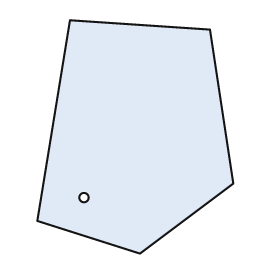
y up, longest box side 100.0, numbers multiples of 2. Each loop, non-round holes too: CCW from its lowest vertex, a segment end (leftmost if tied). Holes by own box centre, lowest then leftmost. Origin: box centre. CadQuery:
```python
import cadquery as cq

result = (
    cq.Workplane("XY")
    .moveTo(2.0, -50.0)
    .lineTo(42.0, -20.0)
    .lineTo(32.0, 46.0)
    .lineTo(-28.0, 50.0)
    .lineTo(-42.0, -36.0)
    .close()
    .moveTo(-22.0, -26.0)
    .circle(2.0)
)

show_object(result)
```